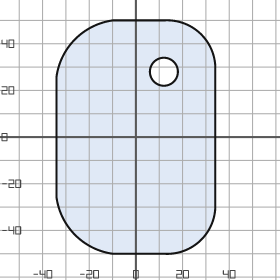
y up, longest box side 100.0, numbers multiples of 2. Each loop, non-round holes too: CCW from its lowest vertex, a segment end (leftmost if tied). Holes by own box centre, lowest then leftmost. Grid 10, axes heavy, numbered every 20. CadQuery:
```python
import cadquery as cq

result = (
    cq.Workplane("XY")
    .moveTo(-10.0, -50.0)
    .lineTo(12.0, -50.0)
    .threePointArc((28.0, -44.0), (34.0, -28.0))
    .lineTo(34.0, 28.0)
    .threePointArc((28.0, 44.0), (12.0, 50.0))
    .lineTo(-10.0, 50.0)
    .threePointArc((-26.0, 42.0), (-34.0, 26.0))
    .lineTo(-34.0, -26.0)
    .threePointArc((-26.0, -42.0), (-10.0, -50.0))
    .close()
    .moveTo(12.0, 28.0)
    .circle(6.0)
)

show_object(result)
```